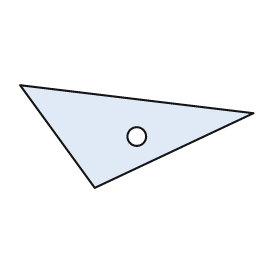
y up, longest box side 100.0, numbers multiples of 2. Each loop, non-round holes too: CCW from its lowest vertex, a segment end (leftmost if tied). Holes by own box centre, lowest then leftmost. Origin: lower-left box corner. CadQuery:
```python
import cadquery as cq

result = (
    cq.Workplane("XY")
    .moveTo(32.0, 0.0)
    .lineTo(100.0, 32.0)
    .lineTo(0.0, 44.0)
    .close()
    .moveTo(50.0, 22.0)
    .circle(4.0)
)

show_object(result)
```